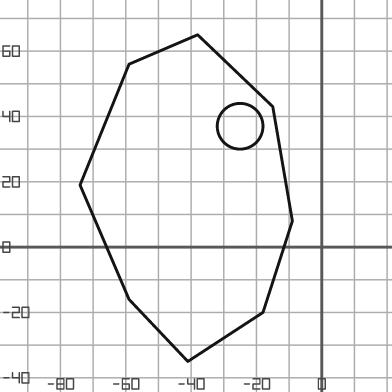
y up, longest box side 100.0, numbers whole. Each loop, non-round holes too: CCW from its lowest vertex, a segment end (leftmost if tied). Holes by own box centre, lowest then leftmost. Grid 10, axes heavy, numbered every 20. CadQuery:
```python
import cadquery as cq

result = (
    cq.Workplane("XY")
    .moveTo(-41.0, -35.0)
    .lineTo(-18.0, -20.0)
    .lineTo(-9.0, 8.0)
    .lineTo(-15.0, 43.0)
    .lineTo(-38.0, 65.0)
    .lineTo(-59.0, 56.0)
    .lineTo(-74.0, 19.0)
    .lineTo(-59.0, -16.0)
    .close()
    .moveTo(-25.0, 37.0)
    .circle(7.0)
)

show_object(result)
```